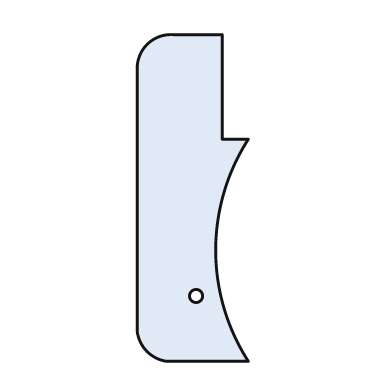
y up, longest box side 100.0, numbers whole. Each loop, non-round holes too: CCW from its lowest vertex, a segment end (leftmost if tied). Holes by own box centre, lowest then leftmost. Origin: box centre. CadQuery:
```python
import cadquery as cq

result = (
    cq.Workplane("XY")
    .moveTo(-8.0, -50.0)
    .lineTo(17.0, -50.0)
    .threePointArc((7.0, -16.0), (17.0, 18.0))
    .lineTo(9.0, 18.0)
    .lineTo(9.0, 50.0)
    .lineTo(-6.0, 50.0)
    .threePointArc((-14.0, 47.0), (-17.0, 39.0))
    .lineTo(-17.0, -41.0)
    .threePointArc((-14.0, -47.0), (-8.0, -50.0))
    .close()
    .moveTo(1.0, -30.0)
    .circle(2.0)
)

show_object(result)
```